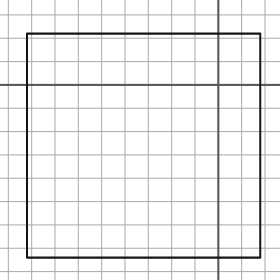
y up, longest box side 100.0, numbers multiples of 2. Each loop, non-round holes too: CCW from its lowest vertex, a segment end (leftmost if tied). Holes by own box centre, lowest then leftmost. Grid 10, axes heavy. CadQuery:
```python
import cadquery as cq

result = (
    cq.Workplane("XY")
    .moveTo(-82.0, -74.0)
    .lineTo(18.0, -74.0)
    .lineTo(18.0, 22.0)
    .lineTo(-82.0, 22.0)
    .close()
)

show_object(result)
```